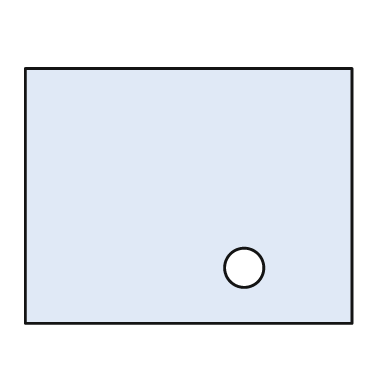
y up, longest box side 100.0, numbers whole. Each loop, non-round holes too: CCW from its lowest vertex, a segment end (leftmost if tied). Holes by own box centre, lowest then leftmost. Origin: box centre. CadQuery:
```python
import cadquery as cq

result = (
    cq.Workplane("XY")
    .moveTo(-50.0, -39.0)
    .lineTo(50.0, -39.0)
    .lineTo(50.0, 39.0)
    .lineTo(-50.0, 39.0)
    .close()
    .moveTo(17.0, -22.0)
    .circle(6.0)
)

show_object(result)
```